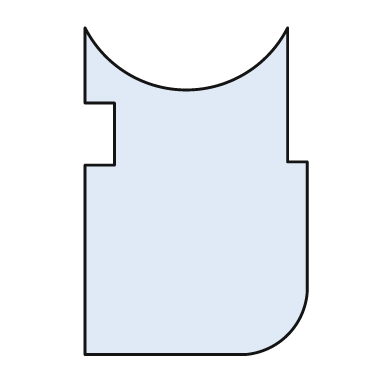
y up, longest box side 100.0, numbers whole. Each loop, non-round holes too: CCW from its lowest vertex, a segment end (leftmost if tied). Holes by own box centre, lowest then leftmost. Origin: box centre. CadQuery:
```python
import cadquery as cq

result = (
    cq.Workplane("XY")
    .moveTo(-34.0, -50.0)
    .lineTo(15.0, -50.0)
    .threePointArc((28.0, -44.0), (34.0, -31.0))
    .lineTo(34.0, 9.0)
    .lineTo(28.0, 9.0)
    .lineTo(28.0, 50.0)
    .threePointArc((-3.0, 31.0), (-34.0, 50.0))
    .lineTo(-34.0, 27.0)
    .lineTo(-25.0, 27.0)
    .lineTo(-25.0, 8.0)
    .lineTo(-34.0, 8.0)
    .close()
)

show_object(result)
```